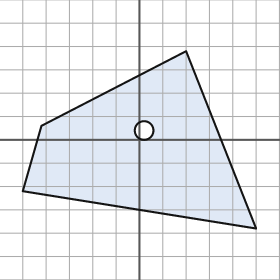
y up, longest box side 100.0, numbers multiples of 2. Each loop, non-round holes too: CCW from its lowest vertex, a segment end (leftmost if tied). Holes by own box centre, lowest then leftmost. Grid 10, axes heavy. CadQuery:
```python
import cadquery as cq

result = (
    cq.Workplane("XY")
    .moveTo(50.0, -38.0)
    .lineTo(20.0, 38.0)
    .lineTo(-42.0, 6.0)
    .lineTo(-50.0, -22.0)
    .close()
    .moveTo(2.0, 4.0)
    .circle(4.0)
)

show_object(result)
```